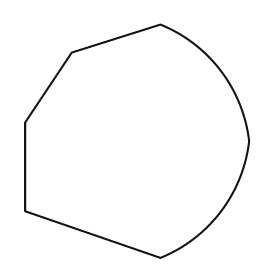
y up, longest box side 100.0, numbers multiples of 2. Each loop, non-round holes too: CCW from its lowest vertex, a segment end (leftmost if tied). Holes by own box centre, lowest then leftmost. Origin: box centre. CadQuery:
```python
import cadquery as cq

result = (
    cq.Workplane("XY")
    .moveTo(10.0, -50.0)
    .threePointArc((36.0, -30.0), (48.0, 0.0))
    .threePointArc((36.0, 30.0), (10.0, 50.0))
    .lineTo(-28.0, 38.0)
    .lineTo(-48.0, 8.0)
    .lineTo(-48.0, -30.0)
    .close()
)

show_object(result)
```